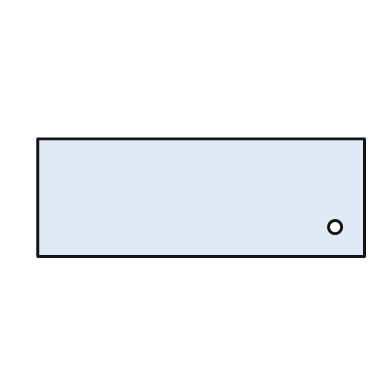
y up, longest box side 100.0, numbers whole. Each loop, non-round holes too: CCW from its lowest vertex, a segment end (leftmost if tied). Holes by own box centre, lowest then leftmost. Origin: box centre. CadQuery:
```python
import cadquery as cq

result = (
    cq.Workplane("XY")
    .moveTo(-50.0, -18.0)
    .lineTo(50.0, -18.0)
    .lineTo(50.0, 18.0)
    .lineTo(-50.0, 18.0)
    .close()
    .moveTo(41.0, -9.0)
    .circle(2.0)
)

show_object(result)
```